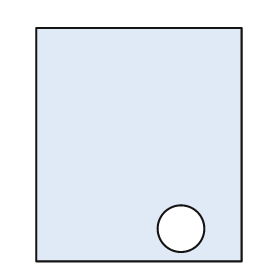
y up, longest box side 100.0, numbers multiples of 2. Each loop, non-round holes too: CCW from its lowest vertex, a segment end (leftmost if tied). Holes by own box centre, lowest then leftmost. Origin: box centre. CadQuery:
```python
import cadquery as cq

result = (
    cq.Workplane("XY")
    .moveTo(-44.0, -50.0)
    .lineTo(44.0, -50.0)
    .lineTo(44.0, 50.0)
    .lineTo(-44.0, 50.0)
    .close()
    .moveTo(18.0, -36.0)
    .circle(10.0)
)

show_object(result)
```